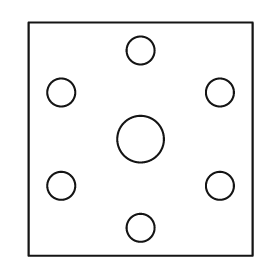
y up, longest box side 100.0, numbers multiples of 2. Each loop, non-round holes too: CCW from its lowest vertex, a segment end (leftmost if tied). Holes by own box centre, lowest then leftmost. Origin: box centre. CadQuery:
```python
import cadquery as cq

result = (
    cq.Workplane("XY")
    .moveTo(-48.0, -50.0)
    .lineTo(48.0, -50.0)
    .lineTo(48.0, 50.0)
    .lineTo(-48.0, 50.0)
    .close()
    .moveTo(0.0, -38.0)
    .circle(6.0)
    .moveTo(-34.0, -20.0)
    .circle(6.0)
    .moveTo(34.0, -20.0)
    .circle(6.0)
    .moveTo(0.0, 0.0)
    .circle(10.0)
    .moveTo(-34.0, 20.0)
    .circle(6.0)
    .moveTo(34.0, 20.0)
    .circle(6.0)
    .moveTo(0.0, 38.0)
    .circle(6.0)
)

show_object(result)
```